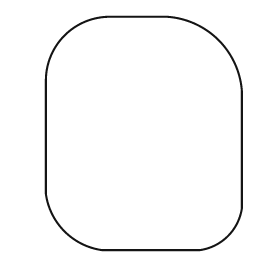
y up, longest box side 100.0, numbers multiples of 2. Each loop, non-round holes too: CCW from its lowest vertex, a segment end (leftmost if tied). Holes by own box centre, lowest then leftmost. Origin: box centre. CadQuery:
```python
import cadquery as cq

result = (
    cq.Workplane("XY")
    .moveTo(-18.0, -50.0)
    .lineTo(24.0, -50.0)
    .threePointArc((36.0, -44.0), (42.0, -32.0))
    .lineTo(42.0, 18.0)
    .threePointArc((32.0, 40.0), (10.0, 50.0))
    .lineTo(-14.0, 50.0)
    .threePointArc((-34.0, 42.0), (-42.0, 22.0))
    .lineTo(-42.0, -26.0)
    .threePointArc((-34.0, -42.0), (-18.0, -50.0))
    .close()
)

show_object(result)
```